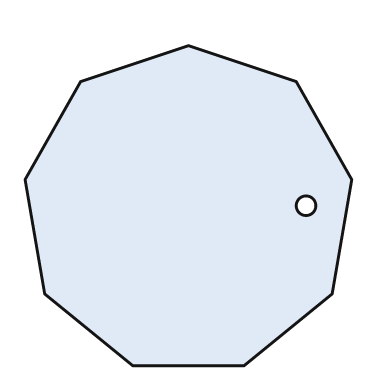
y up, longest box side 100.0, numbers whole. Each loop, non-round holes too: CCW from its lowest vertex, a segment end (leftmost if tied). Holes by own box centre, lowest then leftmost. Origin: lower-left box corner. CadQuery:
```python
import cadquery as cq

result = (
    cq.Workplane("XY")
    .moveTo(33.0, 0.0)
    .lineTo(67.0, 0.0)
    .lineTo(94.0, 22.0)
    .lineTo(100.0, 57.0)
    .lineTo(83.0, 87.0)
    .lineTo(50.0, 98.0)
    .lineTo(17.0, 87.0)
    .lineTo(0.0, 57.0)
    .lineTo(6.0, 22.0)
    .close()
    .moveTo(86.0, 49.0)
    .circle(3.0)
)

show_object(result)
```